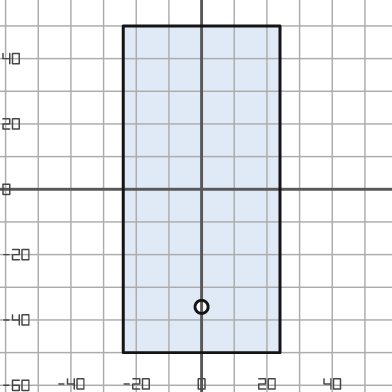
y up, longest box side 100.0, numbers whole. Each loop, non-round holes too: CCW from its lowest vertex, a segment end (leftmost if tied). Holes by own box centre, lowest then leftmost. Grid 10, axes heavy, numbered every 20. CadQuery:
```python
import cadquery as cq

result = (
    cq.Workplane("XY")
    .moveTo(-24.0, -50.0)
    .lineTo(24.0, -50.0)
    .lineTo(24.0, 50.0)
    .lineTo(-24.0, 50.0)
    .close()
    .moveTo(0.0, -36.0)
    .circle(2.0)
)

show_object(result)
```